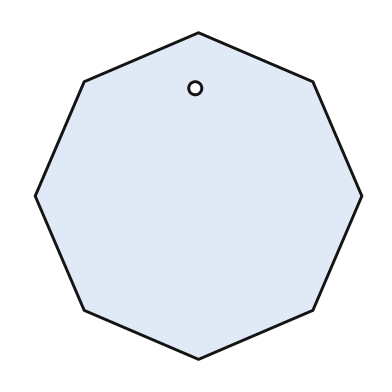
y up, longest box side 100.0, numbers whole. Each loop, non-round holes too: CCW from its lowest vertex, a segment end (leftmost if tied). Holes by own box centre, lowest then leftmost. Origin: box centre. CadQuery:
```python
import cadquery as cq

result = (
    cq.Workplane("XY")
    .moveTo(0.0, -50.0)
    .lineTo(35.0, -35.0)
    .lineTo(50.0, 0.0)
    .lineTo(35.0, 35.0)
    .lineTo(0.0, 50.0)
    .lineTo(-35.0, 35.0)
    .lineTo(-50.0, 0.0)
    .lineTo(-35.0, -35.0)
    .close()
    .moveTo(-1.0, 33.0)
    .circle(2.0)
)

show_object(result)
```